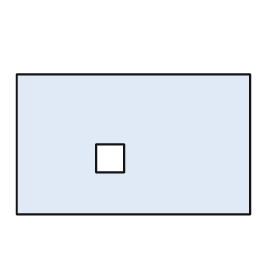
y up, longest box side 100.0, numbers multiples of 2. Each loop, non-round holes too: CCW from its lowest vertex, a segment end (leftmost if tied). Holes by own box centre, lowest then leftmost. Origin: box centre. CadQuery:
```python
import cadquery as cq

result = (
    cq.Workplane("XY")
    .moveTo(-50.0, -30.0)
    .lineTo(50.0, -30.0)
    .lineTo(50.0, 30.0)
    .lineTo(-50.0, 30.0)
    .close()
    .moveTo(-16.0, -12.0)
    .lineTo(-4.0, -12.0)
    .lineTo(-4.0, 0.0)
    .lineTo(-16.0, 0.0)
    .close()
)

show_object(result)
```